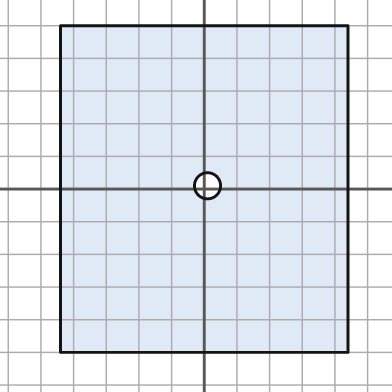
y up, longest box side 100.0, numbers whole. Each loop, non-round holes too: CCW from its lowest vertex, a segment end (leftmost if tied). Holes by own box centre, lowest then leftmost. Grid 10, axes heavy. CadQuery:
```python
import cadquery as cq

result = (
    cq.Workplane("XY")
    .moveTo(-44.0, -50.0)
    .lineTo(44.0, -50.0)
    .lineTo(44.0, 50.0)
    .lineTo(-44.0, 50.0)
    .close()
    .moveTo(1.0, 1.0)
    .circle(4.0)
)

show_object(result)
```